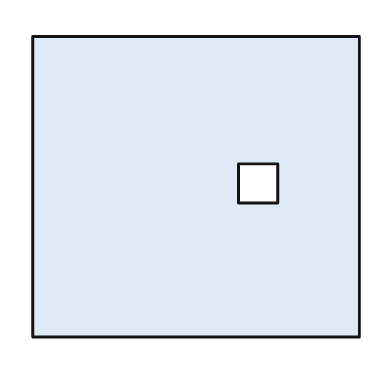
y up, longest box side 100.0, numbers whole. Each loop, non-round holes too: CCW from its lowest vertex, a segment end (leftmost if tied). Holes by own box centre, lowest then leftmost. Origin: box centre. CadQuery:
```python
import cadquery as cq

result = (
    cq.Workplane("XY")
    .moveTo(-50.0, -46.0)
    .lineTo(50.0, -46.0)
    .lineTo(50.0, 46.0)
    .lineTo(-50.0, 46.0)
    .close()
    .moveTo(13.0, -5.0)
    .lineTo(25.0, -5.0)
    .lineTo(25.0, 7.0)
    .lineTo(13.0, 7.0)
    .close()
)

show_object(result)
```